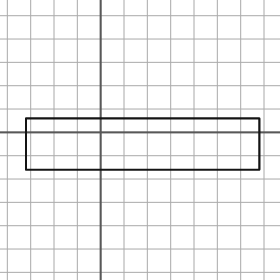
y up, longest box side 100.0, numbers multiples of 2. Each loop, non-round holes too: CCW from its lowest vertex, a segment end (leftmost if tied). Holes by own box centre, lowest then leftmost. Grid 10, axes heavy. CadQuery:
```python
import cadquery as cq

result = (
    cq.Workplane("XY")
    .moveTo(-32.0, -16.0)
    .lineTo(68.0, -16.0)
    .lineTo(68.0, 6.0)
    .lineTo(-32.0, 6.0)
    .close()
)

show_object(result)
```